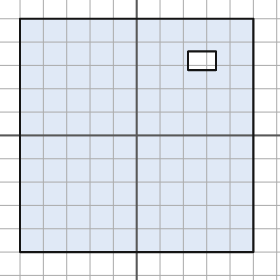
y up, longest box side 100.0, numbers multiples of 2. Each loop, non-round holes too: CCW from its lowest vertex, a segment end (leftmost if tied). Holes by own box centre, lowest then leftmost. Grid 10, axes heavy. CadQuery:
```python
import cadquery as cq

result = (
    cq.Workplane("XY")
    .moveTo(-50.0, -50.0)
    .lineTo(50.0, -50.0)
    .lineTo(50.0, 50.0)
    .lineTo(-50.0, 50.0)
    .close()
    .moveTo(22.0, 28.0)
    .lineTo(34.0, 28.0)
    .lineTo(34.0, 36.0)
    .lineTo(22.0, 36.0)
    .close()
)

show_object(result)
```